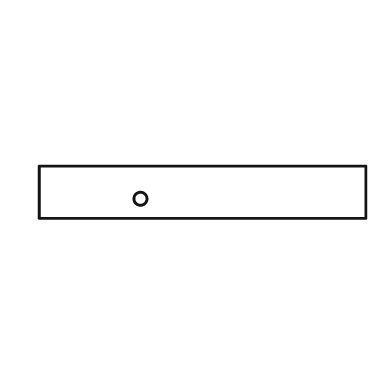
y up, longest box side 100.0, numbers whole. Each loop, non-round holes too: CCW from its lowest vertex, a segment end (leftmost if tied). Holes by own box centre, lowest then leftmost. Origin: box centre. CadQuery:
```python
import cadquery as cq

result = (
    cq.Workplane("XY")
    .moveTo(-50.0, -8.0)
    .lineTo(50.0, -8.0)
    .lineTo(50.0, 8.0)
    .lineTo(-50.0, 8.0)
    .close()
    .moveTo(-19.0, -2.0)
    .circle(2.0)
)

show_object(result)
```